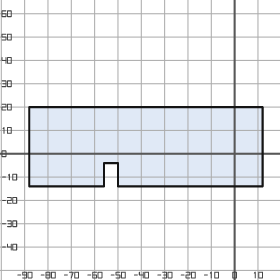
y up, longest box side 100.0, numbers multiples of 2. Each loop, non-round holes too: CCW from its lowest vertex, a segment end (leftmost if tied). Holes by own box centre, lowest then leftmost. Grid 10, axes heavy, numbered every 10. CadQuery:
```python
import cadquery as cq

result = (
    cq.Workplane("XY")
    .moveTo(-88.0, -14.0)
    .lineTo(-56.0, -14.0)
    .lineTo(-56.0, -4.0)
    .lineTo(-50.0, -4.0)
    .lineTo(-50.0, -14.0)
    .lineTo(12.0, -14.0)
    .lineTo(12.0, 20.0)
    .lineTo(-88.0, 20.0)
    .close()
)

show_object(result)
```